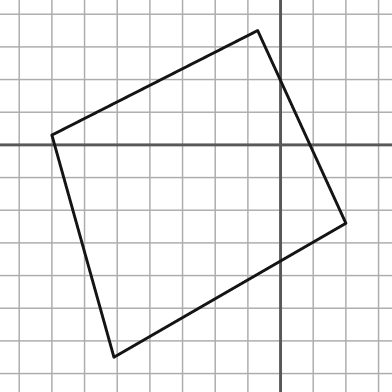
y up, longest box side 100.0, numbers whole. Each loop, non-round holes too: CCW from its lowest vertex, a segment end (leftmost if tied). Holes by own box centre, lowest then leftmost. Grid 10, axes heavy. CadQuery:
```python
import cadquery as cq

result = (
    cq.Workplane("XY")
    .moveTo(-51.0, -65.0)
    .lineTo(20.0, -24.0)
    .lineTo(-7.0, 35.0)
    .lineTo(-70.0, 3.0)
    .close()
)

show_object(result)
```